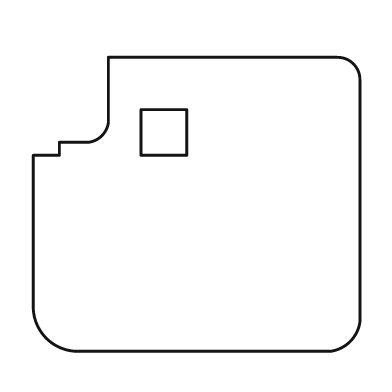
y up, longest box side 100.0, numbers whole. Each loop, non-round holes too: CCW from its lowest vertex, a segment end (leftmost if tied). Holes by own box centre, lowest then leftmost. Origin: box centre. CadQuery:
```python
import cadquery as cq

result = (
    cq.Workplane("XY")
    .moveTo(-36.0, -45.0)
    .lineTo(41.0, -45.0)
    .threePointArc((47.0, -42.0), (50.0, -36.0))
    .lineTo(50.0, 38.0)
    .threePointArc((48.0, 43.0), (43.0, 45.0))
    .lineTo(-27.0, 45.0)
    .lineTo(-27.0, 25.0)
    .threePointArc((-29.0, 21.0), (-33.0, 19.0))
    .lineTo(-42.0, 19.0)
    .lineTo(-42.0, 15.0)
    .lineTo(-50.0, 15.0)
    .lineTo(-50.0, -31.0)
    .threePointArc((-46.0, -41.0), (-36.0, -45.0))
    .close()
    .moveTo(-17.0, 15.0)
    .lineTo(-3.0, 15.0)
    .lineTo(-3.0, 29.0)
    .lineTo(-17.0, 29.0)
    .close()
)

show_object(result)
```